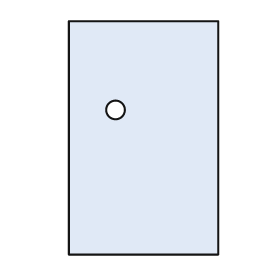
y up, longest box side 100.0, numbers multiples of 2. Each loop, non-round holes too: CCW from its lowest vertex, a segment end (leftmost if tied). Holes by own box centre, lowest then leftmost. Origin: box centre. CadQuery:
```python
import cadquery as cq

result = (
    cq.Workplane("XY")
    .moveTo(-32.0, -50.0)
    .lineTo(32.0, -50.0)
    .lineTo(32.0, 50.0)
    .lineTo(-32.0, 50.0)
    .close()
    .moveTo(-12.0, 12.0)
    .circle(4.0)
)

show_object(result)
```